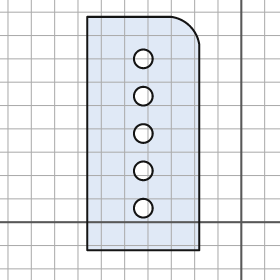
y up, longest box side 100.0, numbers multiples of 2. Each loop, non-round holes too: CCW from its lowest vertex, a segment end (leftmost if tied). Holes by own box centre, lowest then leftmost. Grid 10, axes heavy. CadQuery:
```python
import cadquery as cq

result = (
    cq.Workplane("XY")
    .moveTo(-66.0, -12.0)
    .lineTo(-18.0, -12.0)
    .lineTo(-18.0, 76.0)
    .threePointArc((-22.0, 84.0), (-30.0, 88.0))
    .lineTo(-66.0, 88.0)
    .close()
    .moveTo(-42.0, 6.0)
    .circle(4.0)
    .moveTo(-42.0, 22.0)
    .circle(4.0)
    .moveTo(-42.0, 38.0)
    .circle(4.0)
    .moveTo(-42.0, 54.0)
    .circle(4.0)
    .moveTo(-42.0, 70.0)
    .circle(4.0)
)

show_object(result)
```